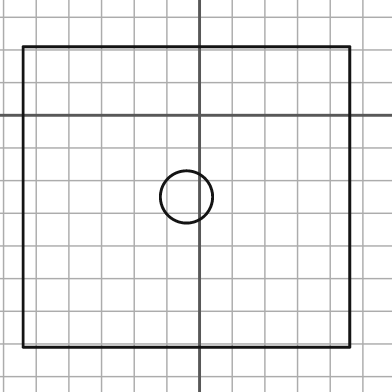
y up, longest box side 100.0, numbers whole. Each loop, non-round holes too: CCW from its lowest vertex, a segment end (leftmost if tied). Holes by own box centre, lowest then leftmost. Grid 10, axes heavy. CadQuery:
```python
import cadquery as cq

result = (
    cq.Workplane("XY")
    .moveTo(-54.0, -71.0)
    .lineTo(46.0, -71.0)
    .lineTo(46.0, 21.0)
    .lineTo(-54.0, 21.0)
    .close()
    .moveTo(-4.0, -25.0)
    .circle(8.0)
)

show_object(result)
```